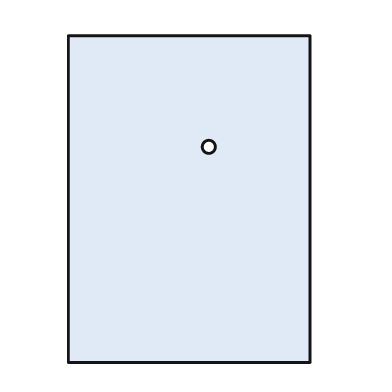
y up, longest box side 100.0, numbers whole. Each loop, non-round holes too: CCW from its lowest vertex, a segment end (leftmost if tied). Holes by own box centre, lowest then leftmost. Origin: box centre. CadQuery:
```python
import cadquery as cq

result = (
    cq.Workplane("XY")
    .moveTo(-37.0, -50.0)
    .lineTo(37.0, -50.0)
    .lineTo(37.0, 50.0)
    .lineTo(-37.0, 50.0)
    .close()
    .moveTo(6.0, 16.0)
    .circle(2.0)
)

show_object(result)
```